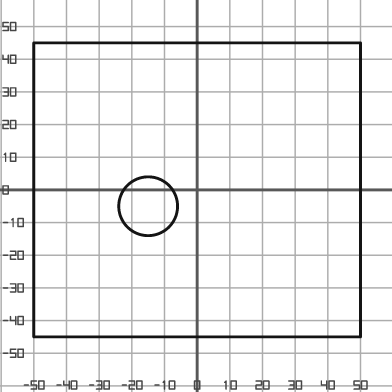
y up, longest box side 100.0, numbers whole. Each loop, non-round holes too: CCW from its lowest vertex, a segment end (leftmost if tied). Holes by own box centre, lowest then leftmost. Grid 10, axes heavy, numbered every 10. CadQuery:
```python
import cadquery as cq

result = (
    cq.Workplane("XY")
    .moveTo(-50.0, -45.0)
    .lineTo(50.0, -45.0)
    .lineTo(50.0, 45.0)
    .lineTo(-50.0, 45.0)
    .close()
    .moveTo(-15.0, -5.0)
    .circle(9.0)
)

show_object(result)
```